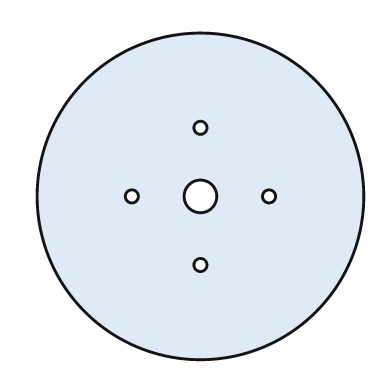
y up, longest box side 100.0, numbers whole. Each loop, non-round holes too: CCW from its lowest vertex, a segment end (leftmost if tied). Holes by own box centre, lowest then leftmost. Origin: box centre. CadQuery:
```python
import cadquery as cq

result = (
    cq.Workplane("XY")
    .moveTo(0.0, 0.0)
    .circle(50.0)
    .moveTo(0.0, -21.0)
    .circle(2.0)
    .moveTo(-21.0, 0.0)
    .circle(2.0)
    .moveTo(0.0, 0.0)
    .circle(5.0)
    .moveTo(21.0, 0.0)
    .circle(2.0)
    .moveTo(0.0, 21.0)
    .circle(2.0)
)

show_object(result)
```